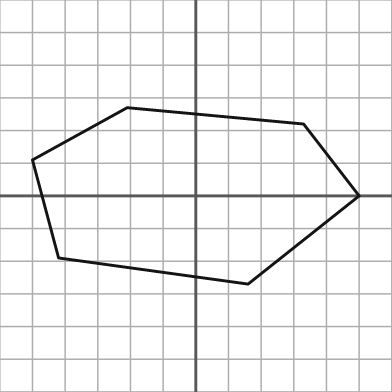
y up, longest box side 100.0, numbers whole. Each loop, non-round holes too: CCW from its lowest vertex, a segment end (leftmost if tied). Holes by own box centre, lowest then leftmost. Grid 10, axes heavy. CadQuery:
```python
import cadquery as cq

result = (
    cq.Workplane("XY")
    .moveTo(16.0, -27.0)
    .lineTo(50.0, 0.0)
    .lineTo(33.0, 22.0)
    .lineTo(-21.0, 27.0)
    .lineTo(-50.0, 11.0)
    .lineTo(-42.0, -19.0)
    .close()
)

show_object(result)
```